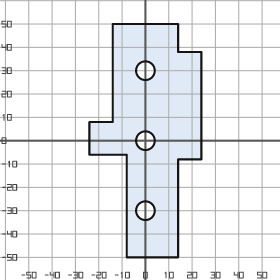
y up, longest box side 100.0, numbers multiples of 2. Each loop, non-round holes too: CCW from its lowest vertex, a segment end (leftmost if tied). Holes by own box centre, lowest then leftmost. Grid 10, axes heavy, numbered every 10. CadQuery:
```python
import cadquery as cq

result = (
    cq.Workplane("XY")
    .moveTo(-8.0, -50.0)
    .lineTo(14.0, -50.0)
    .lineTo(14.0, -8.0)
    .lineTo(24.0, -8.0)
    .lineTo(24.0, 38.0)
    .lineTo(14.0, 38.0)
    .lineTo(14.0, 50.0)
    .lineTo(-14.0, 50.0)
    .lineTo(-14.0, 8.0)
    .lineTo(-24.0, 8.0)
    .lineTo(-24.0, -6.0)
    .lineTo(-8.0, -6.0)
    .close()
    .moveTo(0.0, -30.0)
    .circle(4.0)
    .moveTo(0.0, 0.0)
    .circle(4.0)
    .moveTo(0.0, 30.0)
    .circle(4.0)
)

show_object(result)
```